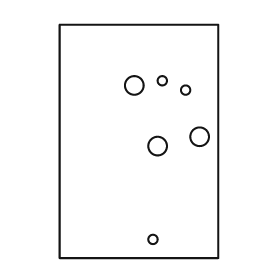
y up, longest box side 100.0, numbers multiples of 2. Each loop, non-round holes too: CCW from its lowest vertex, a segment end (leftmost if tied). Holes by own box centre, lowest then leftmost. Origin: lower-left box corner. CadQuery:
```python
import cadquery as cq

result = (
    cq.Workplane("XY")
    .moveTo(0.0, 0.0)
    .lineTo(68.0, 0.0)
    .lineTo(68.0, 100.0)
    .lineTo(0.0, 100.0)
    .close()
    .moveTo(40.0, 8.0)
    .circle(2.0)
    .moveTo(42.0, 48.0)
    .circle(4.0)
    .moveTo(60.0, 52.0)
    .circle(4.0)
    .moveTo(54.0, 72.0)
    .circle(2.0)
    .moveTo(32.0, 74.0)
    .circle(4.0)
    .moveTo(44.0, 76.0)
    .circle(2.0)
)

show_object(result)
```